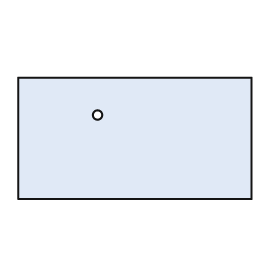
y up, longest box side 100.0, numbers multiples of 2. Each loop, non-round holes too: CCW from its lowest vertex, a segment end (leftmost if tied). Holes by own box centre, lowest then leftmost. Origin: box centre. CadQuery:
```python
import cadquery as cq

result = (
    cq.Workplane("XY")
    .moveTo(-50.0, -26.0)
    .lineTo(50.0, -26.0)
    .lineTo(50.0, 26.0)
    .lineTo(-50.0, 26.0)
    .close()
    .moveTo(-16.0, 10.0)
    .circle(2.0)
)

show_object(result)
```